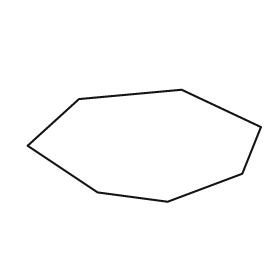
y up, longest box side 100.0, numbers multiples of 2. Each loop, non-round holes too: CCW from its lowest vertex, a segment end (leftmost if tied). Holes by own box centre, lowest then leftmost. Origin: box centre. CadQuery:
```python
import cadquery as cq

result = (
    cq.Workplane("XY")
    .moveTo(10.0, -24.0)
    .lineTo(42.0, -12.0)
    .lineTo(50.0, 8.0)
    .lineTo(16.0, 24.0)
    .lineTo(-28.0, 20.0)
    .lineTo(-50.0, 0.0)
    .lineTo(-20.0, -20.0)
    .close()
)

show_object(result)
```